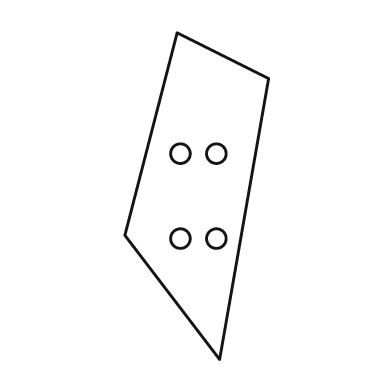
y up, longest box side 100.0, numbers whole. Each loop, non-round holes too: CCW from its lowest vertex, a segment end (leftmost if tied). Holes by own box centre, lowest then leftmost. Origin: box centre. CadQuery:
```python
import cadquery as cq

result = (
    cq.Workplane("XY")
    .moveTo(7.0, -50.0)
    .lineTo(22.0, 36.0)
    .lineTo(-6.0, 50.0)
    .lineTo(-22.0, -12.0)
    .close()
    .moveTo(-5.0, -13.0)
    .circle(3.0)
    .moveTo(6.0, -13.0)
    .circle(3.0)
    .moveTo(-5.0, 13.0)
    .circle(3.0)
    .moveTo(6.0, 13.0)
    .circle(3.0)
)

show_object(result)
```